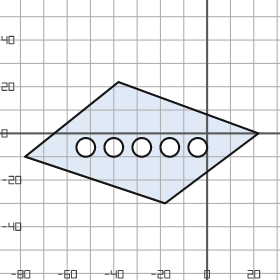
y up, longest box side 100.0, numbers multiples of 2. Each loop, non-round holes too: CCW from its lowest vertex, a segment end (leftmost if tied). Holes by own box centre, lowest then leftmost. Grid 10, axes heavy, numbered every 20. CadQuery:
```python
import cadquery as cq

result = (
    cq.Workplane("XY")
    .moveTo(-18.0, -30.0)
    .lineTo(22.0, 0.0)
    .lineTo(-38.0, 22.0)
    .lineTo(-78.0, -10.0)
    .close()
    .moveTo(-52.0, -6.0)
    .circle(4.0)
    .moveTo(-40.0, -6.0)
    .circle(4.0)
    .moveTo(-28.0, -6.0)
    .circle(4.0)
    .moveTo(-16.0, -6.0)
    .circle(4.0)
    .moveTo(-4.0, -6.0)
    .circle(4.0)
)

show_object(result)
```